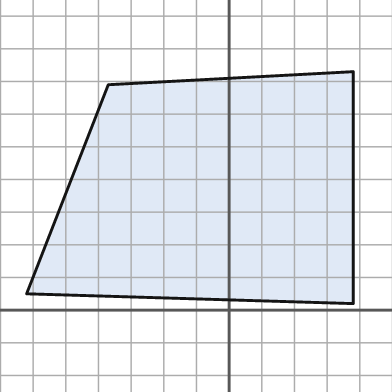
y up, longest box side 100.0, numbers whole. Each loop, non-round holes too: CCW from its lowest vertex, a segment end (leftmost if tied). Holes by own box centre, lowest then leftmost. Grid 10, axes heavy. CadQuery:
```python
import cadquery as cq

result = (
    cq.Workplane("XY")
    .moveTo(38.0, 2.0)
    .lineTo(38.0, 73.0)
    .lineTo(-37.0, 69.0)
    .lineTo(-62.0, 5.0)
    .close()
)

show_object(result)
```